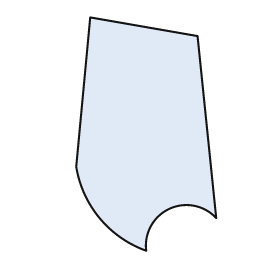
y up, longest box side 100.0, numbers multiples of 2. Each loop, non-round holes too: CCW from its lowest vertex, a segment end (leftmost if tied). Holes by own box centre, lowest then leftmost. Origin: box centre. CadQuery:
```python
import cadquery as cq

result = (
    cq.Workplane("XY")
    .moveTo(0.0, -50.0)
    .threePointArc((10.0, -32.0), (30.0, -36.0))
    .lineTo(22.0, 42.0)
    .lineTo(-24.0, 50.0)
    .lineTo(-30.0, -14.0)
    .threePointArc((-20.0, -36.0), (0.0, -50.0))
    .close()
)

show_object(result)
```